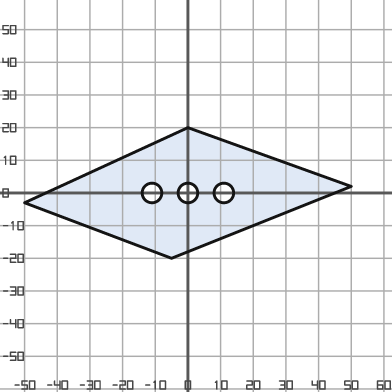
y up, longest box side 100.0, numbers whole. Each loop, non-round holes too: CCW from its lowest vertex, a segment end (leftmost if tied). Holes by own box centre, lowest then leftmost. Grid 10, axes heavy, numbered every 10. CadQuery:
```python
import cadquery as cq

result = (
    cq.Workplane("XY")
    .moveTo(-5.0, -20.0)
    .lineTo(50.0, 2.0)
    .lineTo(0.0, 20.0)
    .lineTo(-50.0, -3.0)
    .close()
    .moveTo(-11.0, 0.0)
    .circle(3.0)
    .moveTo(0.0, 0.0)
    .circle(3.0)
    .moveTo(11.0, 0.0)
    .circle(3.0)
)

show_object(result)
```